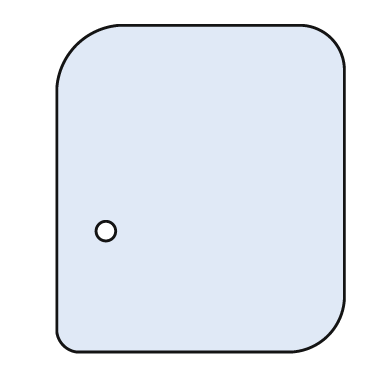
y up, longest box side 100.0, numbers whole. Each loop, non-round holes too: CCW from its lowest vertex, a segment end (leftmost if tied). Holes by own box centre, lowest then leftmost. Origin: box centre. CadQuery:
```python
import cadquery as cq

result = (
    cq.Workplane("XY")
    .moveTo(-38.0, -50.0)
    .lineTo(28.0, -50.0)
    .threePointArc((39.0, -45.0), (44.0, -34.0))
    .lineTo(44.0, 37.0)
    .threePointArc((40.0, 46.0), (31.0, 50.0))
    .lineTo(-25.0, 50.0)
    .threePointArc((-38.0, 44.0), (-44.0, 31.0))
    .lineTo(-44.0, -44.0)
    .threePointArc((-42.0, -48.0), (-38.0, -50.0))
    .close()
    .moveTo(-29.0, -13.0)
    .circle(3.0)
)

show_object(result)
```